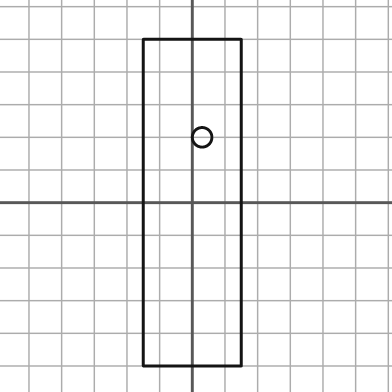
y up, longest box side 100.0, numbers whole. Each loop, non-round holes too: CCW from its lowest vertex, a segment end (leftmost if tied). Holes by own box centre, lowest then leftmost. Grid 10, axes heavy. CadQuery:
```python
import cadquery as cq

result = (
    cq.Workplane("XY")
    .moveTo(-15.0, -50.0)
    .lineTo(15.0, -50.0)
    .lineTo(15.0, 50.0)
    .lineTo(-15.0, 50.0)
    .close()
    .moveTo(3.0, 20.0)
    .circle(3.0)
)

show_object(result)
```